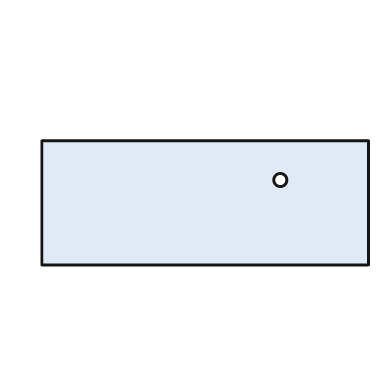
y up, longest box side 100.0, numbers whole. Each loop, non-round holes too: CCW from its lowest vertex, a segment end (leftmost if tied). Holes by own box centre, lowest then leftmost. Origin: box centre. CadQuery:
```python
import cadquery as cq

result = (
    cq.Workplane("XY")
    .moveTo(-50.0, -19.0)
    .lineTo(50.0, -19.0)
    .lineTo(50.0, 19.0)
    .lineTo(-50.0, 19.0)
    .close()
    .moveTo(23.0, 7.0)
    .circle(2.0)
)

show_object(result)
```